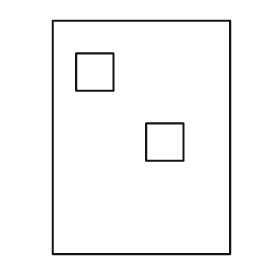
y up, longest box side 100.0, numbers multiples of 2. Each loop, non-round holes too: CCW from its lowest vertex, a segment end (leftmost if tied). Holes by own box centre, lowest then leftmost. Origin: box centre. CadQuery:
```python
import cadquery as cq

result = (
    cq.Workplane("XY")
    .moveTo(-38.0, -50.0)
    .lineTo(38.0, -50.0)
    .lineTo(38.0, 50.0)
    .lineTo(-38.0, 50.0)
    .close()
    .moveTo(2.0, -10.0)
    .lineTo(18.0, -10.0)
    .lineTo(18.0, 6.0)
    .lineTo(2.0, 6.0)
    .close()
    .moveTo(-28.0, 20.0)
    .lineTo(-12.0, 20.0)
    .lineTo(-12.0, 36.0)
    .lineTo(-28.0, 36.0)
    .close()
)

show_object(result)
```